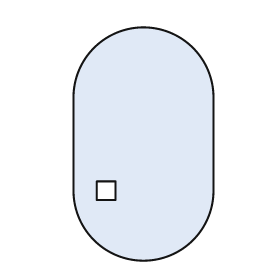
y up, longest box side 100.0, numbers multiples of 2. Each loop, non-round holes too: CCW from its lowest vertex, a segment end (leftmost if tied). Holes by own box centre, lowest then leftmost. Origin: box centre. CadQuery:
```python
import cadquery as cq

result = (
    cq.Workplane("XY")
    .moveTo(-30.0, -20.0)
    .threePointArc((0.0, -50.0), (30.0, -20.0))
    .lineTo(30.0, 20.0)
    .threePointArc((0.0, 50.0), (-30.0, 20.0))
    .close()
    .moveTo(-20.0, -24.0)
    .lineTo(-12.0, -24.0)
    .lineTo(-12.0, -16.0)
    .lineTo(-20.0, -16.0)
    .close()
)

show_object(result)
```